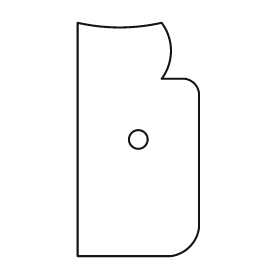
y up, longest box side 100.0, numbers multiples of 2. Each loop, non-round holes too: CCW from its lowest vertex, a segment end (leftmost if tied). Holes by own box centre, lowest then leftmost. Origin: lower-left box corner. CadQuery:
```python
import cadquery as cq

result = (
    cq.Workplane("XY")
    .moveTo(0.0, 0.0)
    .lineTo(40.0, 0.0)
    .threePointArc((48.0, 4.0), (52.0, 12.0))
    .lineTo(52.0, 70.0)
    .threePointArc((50.0, 74.0), (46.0, 76.0))
    .lineTo(36.0, 76.0)
    .threePointArc((40.0, 88.0), (36.0, 100.0))
    .threePointArc((18.0, 98.0), (0.0, 100.0))
    .close()
    .moveTo(26.0, 50.0)
    .circle(4.0)
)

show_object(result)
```